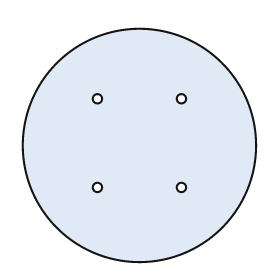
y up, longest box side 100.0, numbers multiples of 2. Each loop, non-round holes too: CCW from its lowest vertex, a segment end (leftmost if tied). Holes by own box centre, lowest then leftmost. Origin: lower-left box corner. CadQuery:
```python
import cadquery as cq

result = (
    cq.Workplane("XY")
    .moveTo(50.0, 50.0)
    .circle(50.0)
    .moveTo(32.0, 32.0)
    .circle(2.0)
    .moveTo(68.0, 32.0)
    .circle(2.0)
    .moveTo(32.0, 70.0)
    .circle(2.0)
    .moveTo(68.0, 70.0)
    .circle(2.0)
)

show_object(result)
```